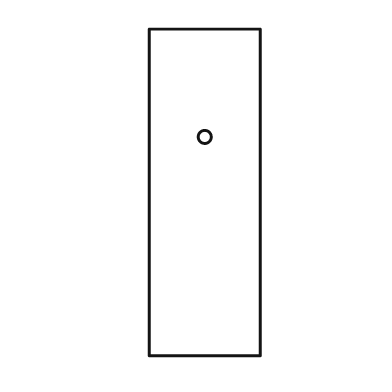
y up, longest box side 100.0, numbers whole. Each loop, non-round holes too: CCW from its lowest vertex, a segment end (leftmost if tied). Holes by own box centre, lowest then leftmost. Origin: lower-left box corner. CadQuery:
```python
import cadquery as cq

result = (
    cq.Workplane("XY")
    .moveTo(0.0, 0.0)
    .lineTo(34.0, 0.0)
    .lineTo(34.0, 100.0)
    .lineTo(0.0, 100.0)
    .close()
    .moveTo(17.0, 67.0)
    .circle(2.0)
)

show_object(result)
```